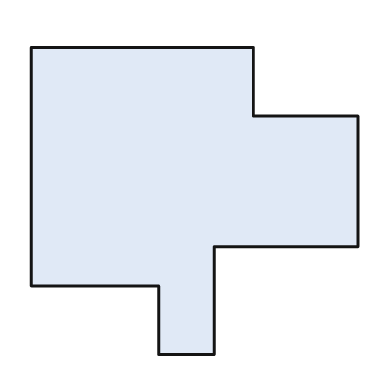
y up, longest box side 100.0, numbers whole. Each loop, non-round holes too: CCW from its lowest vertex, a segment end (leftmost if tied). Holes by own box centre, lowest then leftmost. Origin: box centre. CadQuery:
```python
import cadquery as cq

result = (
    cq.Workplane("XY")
    .moveTo(-11.0, -47.0)
    .lineTo(6.0, -47.0)
    .lineTo(6.0, -14.0)
    .lineTo(50.0, -14.0)
    .lineTo(50.0, 26.0)
    .lineTo(18.0, 26.0)
    .lineTo(18.0, 47.0)
    .lineTo(-50.0, 47.0)
    .lineTo(-50.0, -26.0)
    .lineTo(-11.0, -26.0)
    .close()
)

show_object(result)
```